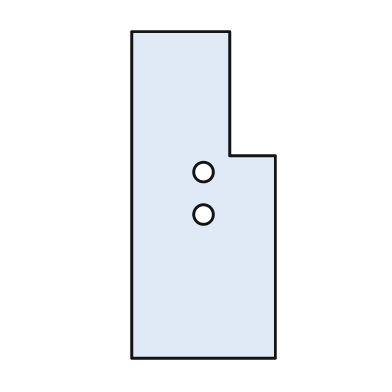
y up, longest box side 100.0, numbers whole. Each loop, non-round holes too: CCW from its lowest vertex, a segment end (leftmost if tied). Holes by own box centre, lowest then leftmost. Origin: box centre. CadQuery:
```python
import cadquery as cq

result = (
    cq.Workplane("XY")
    .moveTo(-22.0, -50.0)
    .lineTo(22.0, -50.0)
    .lineTo(22.0, 12.0)
    .lineTo(8.0, 12.0)
    .lineTo(8.0, 50.0)
    .lineTo(-22.0, 50.0)
    .close()
    .moveTo(0.0, -6.0)
    .circle(3.0)
    .moveTo(0.0, 7.0)
    .circle(3.0)
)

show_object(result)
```